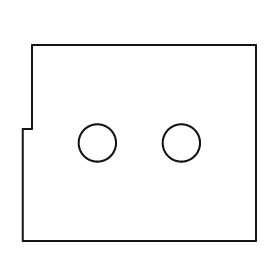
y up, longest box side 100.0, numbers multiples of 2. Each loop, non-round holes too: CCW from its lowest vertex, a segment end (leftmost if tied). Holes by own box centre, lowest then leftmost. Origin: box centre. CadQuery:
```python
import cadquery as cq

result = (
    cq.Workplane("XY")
    .moveTo(-50.0, -42.0)
    .lineTo(50.0, -42.0)
    .lineTo(50.0, 42.0)
    .lineTo(-46.0, 42.0)
    .lineTo(-46.0, 6.0)
    .lineTo(-50.0, 6.0)
    .close()
    .moveTo(-18.0, 0.0)
    .circle(8.0)
    .moveTo(18.0, 0.0)
    .circle(8.0)
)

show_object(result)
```